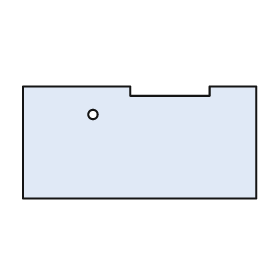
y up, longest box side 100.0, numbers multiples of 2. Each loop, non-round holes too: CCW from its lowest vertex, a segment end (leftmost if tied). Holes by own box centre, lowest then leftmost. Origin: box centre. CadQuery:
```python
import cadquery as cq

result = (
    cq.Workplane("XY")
    .moveTo(-50.0, -24.0)
    .lineTo(50.0, -24.0)
    .lineTo(50.0, 24.0)
    .lineTo(30.0, 24.0)
    .lineTo(30.0, 20.0)
    .lineTo(-4.0, 20.0)
    .lineTo(-4.0, 24.0)
    .lineTo(-50.0, 24.0)
    .close()
    .moveTo(-20.0, 12.0)
    .circle(2.0)
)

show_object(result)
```